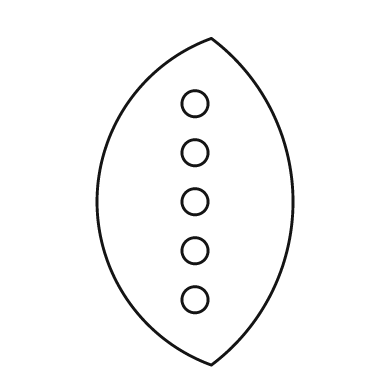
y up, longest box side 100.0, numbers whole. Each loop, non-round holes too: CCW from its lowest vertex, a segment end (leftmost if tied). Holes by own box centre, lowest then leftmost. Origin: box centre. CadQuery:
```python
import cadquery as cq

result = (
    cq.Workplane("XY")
    .moveTo(5.0, -50.0)
    .threePointArc((30.0, 0.0), (5.0, 50.0))
    .threePointArc((-30.0, 0.0), (5.0, -50.0))
    .close()
    .moveTo(0.0, -30.0)
    .circle(4.0)
    .moveTo(0.0, -15.0)
    .circle(4.0)
    .moveTo(0.0, 0.0)
    .circle(4.0)
    .moveTo(0.0, 15.0)
    .circle(4.0)
    .moveTo(0.0, 30.0)
    .circle(4.0)
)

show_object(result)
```